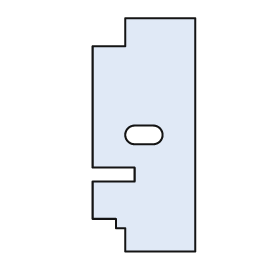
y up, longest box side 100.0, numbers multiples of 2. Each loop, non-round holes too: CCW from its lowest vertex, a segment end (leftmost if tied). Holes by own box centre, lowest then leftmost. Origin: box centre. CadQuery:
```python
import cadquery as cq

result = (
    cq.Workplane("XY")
    .moveTo(-8.0, -50.0)
    .lineTo(22.0, -50.0)
    .lineTo(22.0, 50.0)
    .lineTo(-8.0, 50.0)
    .lineTo(-8.0, 38.0)
    .lineTo(-22.0, 38.0)
    .lineTo(-22.0, -14.0)
    .lineTo(-4.0, -14.0)
    .lineTo(-4.0, -20.0)
    .lineTo(-22.0, -20.0)
    .lineTo(-22.0, -36.0)
    .lineTo(-12.0, -36.0)
    .lineTo(-12.0, -40.0)
    .lineTo(-8.0, -40.0)
    .close()
    .moveTo(-4.0, -4.0)
    .lineTo(4.0, -4.0)
    .threePointArc((8.0, 0.0), (4.0, 4.0))
    .lineTo(-4.0, 4.0)
    .threePointArc((-8.0, 0.0), (-4.0, -4.0))
    .close()
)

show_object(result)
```